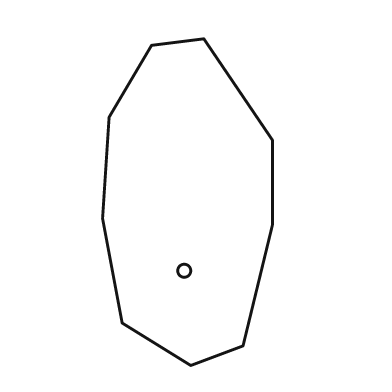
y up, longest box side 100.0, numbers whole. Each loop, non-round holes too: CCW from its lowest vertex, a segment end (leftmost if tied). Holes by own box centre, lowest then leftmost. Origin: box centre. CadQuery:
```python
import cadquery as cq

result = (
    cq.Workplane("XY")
    .moveTo(1.0, -50.0)
    .lineTo(17.0, -44.0)
    .lineTo(26.0, -7.0)
    .lineTo(26.0, 19.0)
    .lineTo(5.0, 50.0)
    .lineTo(-11.0, 48.0)
    .lineTo(-24.0, 26.0)
    .lineTo(-26.0, -5.0)
    .lineTo(-20.0, -37.0)
    .close()
    .moveTo(-1.0, -21.0)
    .circle(2.0)
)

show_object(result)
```